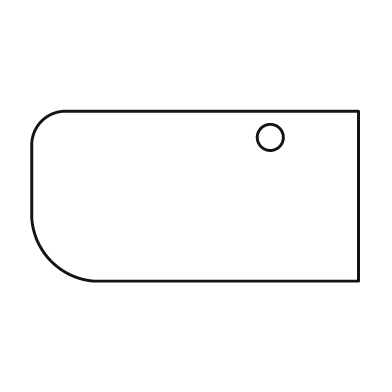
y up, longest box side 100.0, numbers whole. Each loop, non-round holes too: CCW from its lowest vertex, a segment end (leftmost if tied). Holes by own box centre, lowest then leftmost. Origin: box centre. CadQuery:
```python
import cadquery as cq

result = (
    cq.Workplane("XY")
    .moveTo(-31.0, -26.0)
    .lineTo(50.0, -26.0)
    .lineTo(50.0, 26.0)
    .lineTo(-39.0, 26.0)
    .threePointArc((-47.0, 23.0), (-50.0, 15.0))
    .lineTo(-50.0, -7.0)
    .threePointArc((-44.0, -20.0), (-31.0, -26.0))
    .close()
    .moveTo(23.0, 18.0)
    .circle(4.0)
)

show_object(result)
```